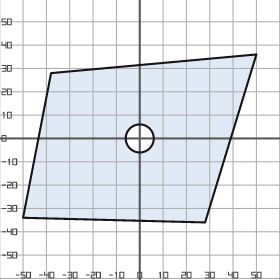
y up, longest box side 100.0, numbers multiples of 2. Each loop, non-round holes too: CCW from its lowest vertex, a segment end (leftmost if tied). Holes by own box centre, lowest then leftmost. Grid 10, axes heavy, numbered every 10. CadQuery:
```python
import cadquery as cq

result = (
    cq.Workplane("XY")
    .moveTo(28.0, -36.0)
    .lineTo(50.0, 36.0)
    .lineTo(-38.0, 28.0)
    .lineTo(-50.0, -34.0)
    .close()
    .moveTo(0.0, 0.0)
    .circle(6.0)
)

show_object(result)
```